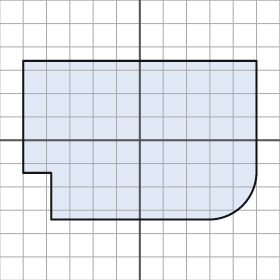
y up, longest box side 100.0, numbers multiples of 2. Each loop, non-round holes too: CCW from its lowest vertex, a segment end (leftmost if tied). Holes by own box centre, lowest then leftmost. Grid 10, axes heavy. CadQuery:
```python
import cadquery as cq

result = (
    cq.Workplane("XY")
    .moveTo(-38.0, -34.0)
    .lineTo(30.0, -34.0)
    .threePointArc((44.0, -28.0), (50.0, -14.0))
    .lineTo(50.0, 34.0)
    .lineTo(-50.0, 34.0)
    .lineTo(-50.0, -14.0)
    .lineTo(-38.0, -14.0)
    .close()
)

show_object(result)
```